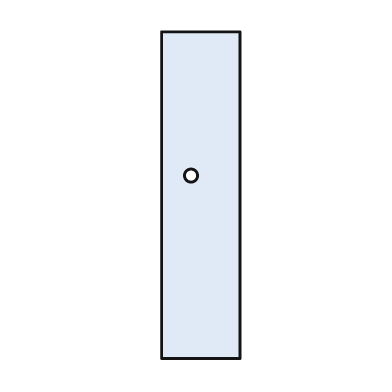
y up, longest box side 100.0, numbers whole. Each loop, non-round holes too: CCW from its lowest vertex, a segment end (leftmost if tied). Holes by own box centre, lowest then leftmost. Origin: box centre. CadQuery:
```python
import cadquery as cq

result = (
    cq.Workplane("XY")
    .moveTo(-12.0, -50.0)
    .lineTo(12.0, -50.0)
    .lineTo(12.0, 50.0)
    .lineTo(-12.0, 50.0)
    .close()
    .moveTo(-3.0, 6.0)
    .circle(2.0)
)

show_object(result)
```